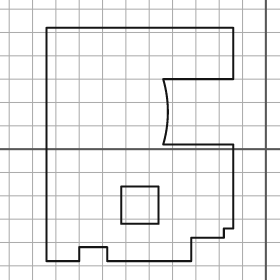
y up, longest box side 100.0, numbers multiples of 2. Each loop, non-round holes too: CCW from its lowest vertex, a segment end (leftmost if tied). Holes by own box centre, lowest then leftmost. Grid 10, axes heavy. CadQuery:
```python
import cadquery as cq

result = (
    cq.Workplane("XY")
    .moveTo(-94.0, -48.0)
    .lineTo(-80.0, -48.0)
    .lineTo(-80.0, -42.0)
    .lineTo(-68.0, -42.0)
    .lineTo(-68.0, -48.0)
    .lineTo(-32.0, -48.0)
    .lineTo(-32.0, -38.0)
    .lineTo(-18.0, -38.0)
    .lineTo(-18.0, -34.0)
    .lineTo(-14.0, -34.0)
    .lineTo(-14.0, 2.0)
    .lineTo(-44.0, 2.0)
    .threePointArc((-42.0, 16.0), (-44.0, 30.0))
    .lineTo(-14.0, 30.0)
    .lineTo(-14.0, 52.0)
    .lineTo(-94.0, 52.0)
    .close()
    .moveTo(-62.0, -32.0)
    .lineTo(-46.0, -32.0)
    .lineTo(-46.0, -16.0)
    .lineTo(-62.0, -16.0)
    .close()
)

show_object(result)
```